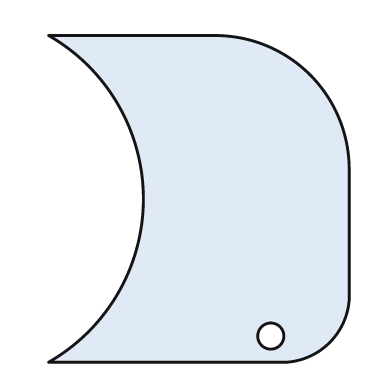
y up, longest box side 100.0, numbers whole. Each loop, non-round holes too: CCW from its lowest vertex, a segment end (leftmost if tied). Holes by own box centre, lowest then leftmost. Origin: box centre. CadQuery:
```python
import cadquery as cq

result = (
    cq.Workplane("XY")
    .moveTo(-46.0, -50.0)
    .lineTo(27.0, -50.0)
    .threePointArc((40.0, -44.0), (46.0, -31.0))
    .lineTo(46.0, 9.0)
    .threePointArc((34.0, 38.0), (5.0, 50.0))
    .lineTo(-46.0, 50.0)
    .threePointArc((-17.0, 0.0), (-46.0, -50.0))
    .close()
    .moveTo(22.0, -42.0)
    .circle(4.0)
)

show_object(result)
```